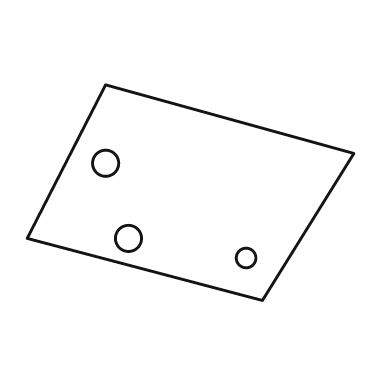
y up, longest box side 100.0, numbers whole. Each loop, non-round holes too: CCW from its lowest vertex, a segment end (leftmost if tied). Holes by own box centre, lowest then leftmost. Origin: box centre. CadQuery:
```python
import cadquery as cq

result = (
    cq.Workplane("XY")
    .moveTo(22.0, -33.0)
    .lineTo(50.0, 12.0)
    .lineTo(-26.0, 33.0)
    .lineTo(-50.0, -14.0)
    .close()
    .moveTo(17.0, -20.0)
    .circle(3.0)
    .moveTo(-19.0, -14.0)
    .circle(4.0)
    .moveTo(-26.0, 9.0)
    .circle(4.0)
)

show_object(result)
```